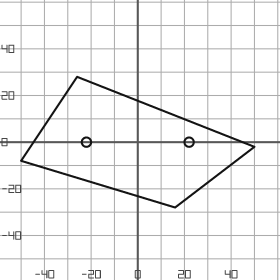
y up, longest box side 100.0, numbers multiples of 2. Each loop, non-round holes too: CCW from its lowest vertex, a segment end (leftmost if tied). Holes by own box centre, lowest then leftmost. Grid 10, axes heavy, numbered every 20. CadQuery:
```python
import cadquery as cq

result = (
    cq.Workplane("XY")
    .moveTo(16.0, -28.0)
    .lineTo(50.0, -2.0)
    .lineTo(-26.0, 28.0)
    .lineTo(-50.0, -8.0)
    .close()
    .moveTo(-22.0, 0.0)
    .circle(2.0)
    .moveTo(22.0, 0.0)
    .circle(2.0)
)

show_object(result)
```